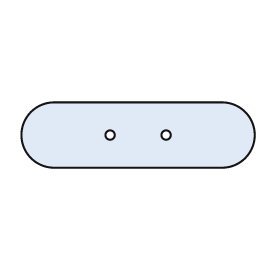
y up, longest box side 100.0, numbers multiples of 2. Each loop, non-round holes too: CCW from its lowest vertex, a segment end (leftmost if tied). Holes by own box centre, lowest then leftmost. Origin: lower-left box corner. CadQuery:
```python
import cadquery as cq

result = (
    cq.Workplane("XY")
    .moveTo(14.0, 0.0)
    .lineTo(86.0, 0.0)
    .threePointArc((100.0, 14.0), (86.0, 28.0))
    .lineTo(14.0, 28.0)
    .threePointArc((0.0, 14.0), (14.0, 0.0))
    .close()
    .moveTo(38.0, 14.0)
    .circle(2.0)
    .moveTo(62.0, 14.0)
    .circle(2.0)
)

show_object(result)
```